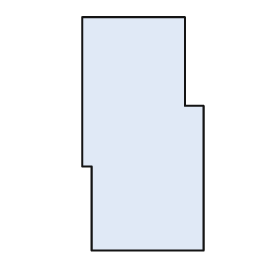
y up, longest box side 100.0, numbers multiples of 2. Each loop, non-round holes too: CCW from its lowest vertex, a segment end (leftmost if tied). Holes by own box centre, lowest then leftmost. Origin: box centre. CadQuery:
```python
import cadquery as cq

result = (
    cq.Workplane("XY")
    .moveTo(-22.0, -50.0)
    .lineTo(26.0, -50.0)
    .lineTo(26.0, 12.0)
    .lineTo(18.0, 12.0)
    .lineTo(18.0, 50.0)
    .lineTo(-26.0, 50.0)
    .lineTo(-26.0, -14.0)
    .lineTo(-22.0, -14.0)
    .close()
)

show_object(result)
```